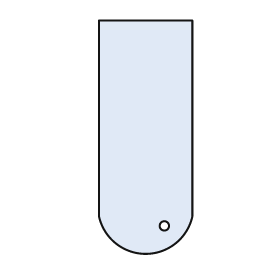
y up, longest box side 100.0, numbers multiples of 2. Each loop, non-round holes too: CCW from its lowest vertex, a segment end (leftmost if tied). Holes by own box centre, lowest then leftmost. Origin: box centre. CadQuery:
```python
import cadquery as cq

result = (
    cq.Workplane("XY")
    .moveTo(-20.0, -34.0)
    .threePointArc((0.0, -50.0), (20.0, -34.0))
    .lineTo(20.0, 50.0)
    .lineTo(-20.0, 50.0)
    .close()
    .moveTo(8.0, -38.0)
    .circle(2.0)
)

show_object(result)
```